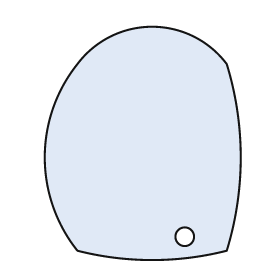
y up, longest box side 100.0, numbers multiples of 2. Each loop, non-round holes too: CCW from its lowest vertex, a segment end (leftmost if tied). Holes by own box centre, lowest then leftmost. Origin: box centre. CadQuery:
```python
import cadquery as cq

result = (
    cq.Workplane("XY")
    .moveTo(-28.0, -46.0)
    .threePointArc((4.0, -50.0), (36.0, -46.0))
    .threePointArc((42.0, -6.0), (36.0, 34.0))
    .threePointArc((4.0, 50.0), (-28.0, 34.0))
    .threePointArc((-42.0, -6.0), (-28.0, -46.0))
    .close()
    .moveTo(18.0, -40.0)
    .circle(4.0)
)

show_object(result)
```